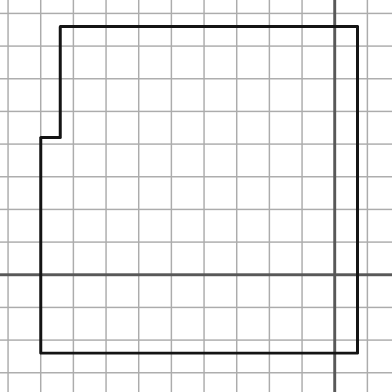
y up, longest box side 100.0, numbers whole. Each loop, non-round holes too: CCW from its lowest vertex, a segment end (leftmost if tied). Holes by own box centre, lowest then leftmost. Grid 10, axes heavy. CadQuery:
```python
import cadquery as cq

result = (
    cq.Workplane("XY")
    .moveTo(-90.0, -24.0)
    .lineTo(7.0, -24.0)
    .lineTo(7.0, 76.0)
    .lineTo(-84.0, 76.0)
    .lineTo(-84.0, 42.0)
    .lineTo(-90.0, 42.0)
    .close()
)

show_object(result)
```